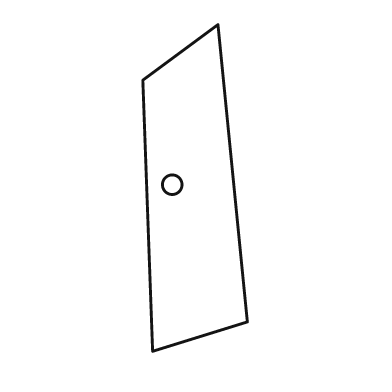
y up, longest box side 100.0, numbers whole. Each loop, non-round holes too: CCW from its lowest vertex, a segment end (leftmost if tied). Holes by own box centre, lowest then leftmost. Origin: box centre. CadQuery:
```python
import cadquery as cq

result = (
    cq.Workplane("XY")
    .moveTo(-13.0, -50.0)
    .lineTo(16.0, -41.0)
    .lineTo(7.0, 50.0)
    .lineTo(-16.0, 33.0)
    .close()
    .moveTo(-7.0, 1.0)
    .circle(3.0)
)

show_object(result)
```